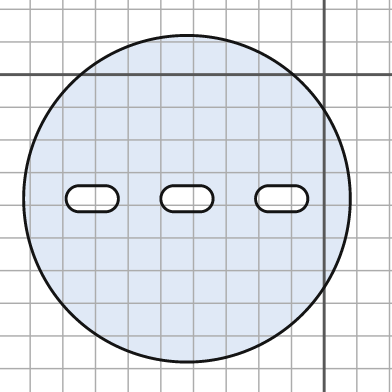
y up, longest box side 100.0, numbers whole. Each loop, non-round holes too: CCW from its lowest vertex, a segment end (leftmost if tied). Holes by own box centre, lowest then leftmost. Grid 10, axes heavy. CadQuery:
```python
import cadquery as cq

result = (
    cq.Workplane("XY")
    .moveTo(-42.0, -38.0)
    .circle(50.0)
    .moveTo(-75.0, -42.0)
    .lineTo(-67.0, -42.0)
    .threePointArc((-63.0, -38.0), (-67.0, -34.0))
    .lineTo(-75.0, -34.0)
    .threePointArc((-79.0, -38.0), (-75.0, -42.0))
    .close()
    .moveTo(-46.0, -42.0)
    .lineTo(-38.0, -42.0)
    .threePointArc((-34.0, -38.0), (-38.0, -34.0))
    .lineTo(-46.0, -34.0)
    .threePointArc((-50.0, -38.0), (-46.0, -42.0))
    .close()
    .moveTo(-17.0, -42.0)
    .lineTo(-9.0, -42.0)
    .threePointArc((-5.0, -38.0), (-9.0, -34.0))
    .lineTo(-17.0, -34.0)
    .threePointArc((-21.0, -38.0), (-17.0, -42.0))
    .close()
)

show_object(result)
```